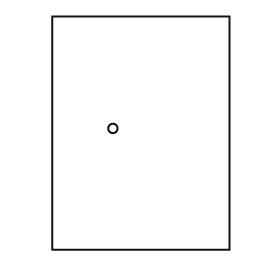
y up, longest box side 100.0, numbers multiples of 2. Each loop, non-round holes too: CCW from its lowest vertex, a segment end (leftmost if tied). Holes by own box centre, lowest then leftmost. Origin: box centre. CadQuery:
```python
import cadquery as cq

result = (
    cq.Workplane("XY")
    .moveTo(-38.0, -50.0)
    .lineTo(38.0, -50.0)
    .lineTo(38.0, 50.0)
    .lineTo(-38.0, 50.0)
    .close()
    .moveTo(-12.0, 2.0)
    .circle(2.0)
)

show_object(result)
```